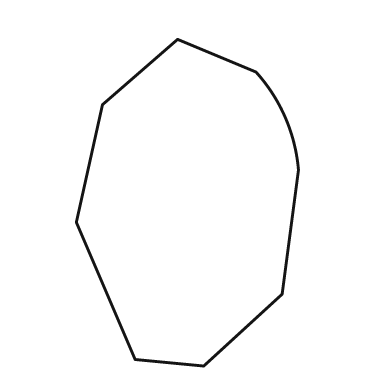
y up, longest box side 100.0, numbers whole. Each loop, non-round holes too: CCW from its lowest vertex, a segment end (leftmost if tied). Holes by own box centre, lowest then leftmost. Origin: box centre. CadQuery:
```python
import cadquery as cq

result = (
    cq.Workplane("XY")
    .moveTo(5.0, -50.0)
    .lineTo(29.0, -28.0)
    .lineTo(34.0, 10.0)
    .threePointArc((30.0, 26.0), (21.0, 40.0))
    .lineTo(-3.0, 50.0)
    .lineTo(-26.0, 30.0)
    .lineTo(-34.0, -6.0)
    .lineTo(-16.0, -48.0)
    .close()
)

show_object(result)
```